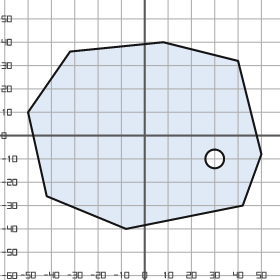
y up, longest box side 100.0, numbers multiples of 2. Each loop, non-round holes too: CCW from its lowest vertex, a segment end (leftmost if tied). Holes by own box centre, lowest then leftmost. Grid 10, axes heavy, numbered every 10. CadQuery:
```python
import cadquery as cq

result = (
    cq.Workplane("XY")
    .moveTo(-8.0, -40.0)
    .lineTo(42.0, -30.0)
    .lineTo(50.0, -8.0)
    .lineTo(40.0, 32.0)
    .lineTo(8.0, 40.0)
    .lineTo(-32.0, 36.0)
    .lineTo(-50.0, 10.0)
    .lineTo(-42.0, -26.0)
    .close()
    .moveTo(30.0, -10.0)
    .circle(4.0)
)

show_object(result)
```